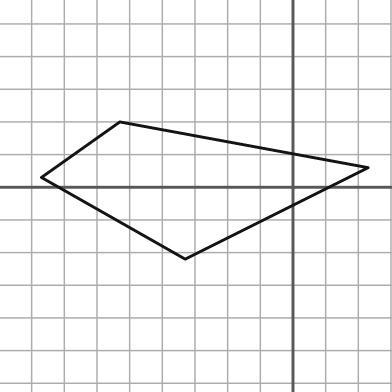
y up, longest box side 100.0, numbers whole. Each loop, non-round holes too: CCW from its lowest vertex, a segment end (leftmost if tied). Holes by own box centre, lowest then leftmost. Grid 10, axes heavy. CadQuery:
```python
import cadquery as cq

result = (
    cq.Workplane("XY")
    .moveTo(-33.0, -22.0)
    .lineTo(23.0, 6.0)
    .lineTo(-53.0, 20.0)
    .lineTo(-77.0, 3.0)
    .close()
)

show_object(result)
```